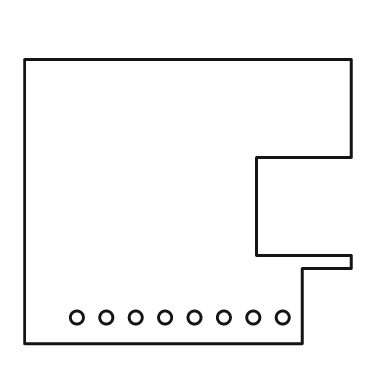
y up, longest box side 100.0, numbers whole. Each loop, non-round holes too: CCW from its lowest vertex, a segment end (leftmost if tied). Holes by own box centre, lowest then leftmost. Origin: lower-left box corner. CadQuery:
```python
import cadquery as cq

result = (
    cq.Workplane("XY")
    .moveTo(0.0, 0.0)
    .lineTo(85.0, 0.0)
    .lineTo(85.0, 23.0)
    .lineTo(100.0, 23.0)
    .lineTo(100.0, 27.0)
    .lineTo(71.0, 27.0)
    .lineTo(71.0, 57.0)
    .lineTo(100.0, 57.0)
    .lineTo(100.0, 87.0)
    .lineTo(0.0, 87.0)
    .close()
    .moveTo(16.0, 8.0)
    .circle(2.0)
    .moveTo(25.0, 8.0)
    .circle(2.0)
    .moveTo(34.0, 8.0)
    .circle(2.0)
    .moveTo(43.0, 8.0)
    .circle(2.0)
    .moveTo(52.0, 8.0)
    .circle(2.0)
    .moveTo(61.0, 8.0)
    .circle(2.0)
    .moveTo(70.0, 8.0)
    .circle(2.0)
    .moveTo(79.0, 8.0)
    .circle(2.0)
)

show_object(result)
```